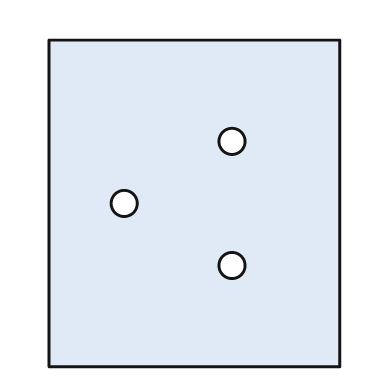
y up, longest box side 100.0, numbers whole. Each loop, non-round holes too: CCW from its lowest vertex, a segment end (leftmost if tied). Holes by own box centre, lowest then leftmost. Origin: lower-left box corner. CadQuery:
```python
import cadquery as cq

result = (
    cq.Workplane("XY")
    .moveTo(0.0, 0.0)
    .lineTo(89.0, 0.0)
    .lineTo(89.0, 100.0)
    .lineTo(0.0, 100.0)
    .close()
    .moveTo(56.0, 31.0)
    .circle(4.0)
    .moveTo(23.0, 50.0)
    .circle(4.0)
    .moveTo(56.0, 69.0)
    .circle(4.0)
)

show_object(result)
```